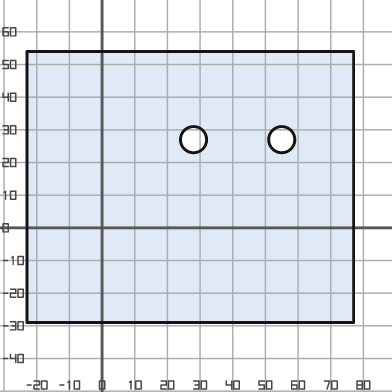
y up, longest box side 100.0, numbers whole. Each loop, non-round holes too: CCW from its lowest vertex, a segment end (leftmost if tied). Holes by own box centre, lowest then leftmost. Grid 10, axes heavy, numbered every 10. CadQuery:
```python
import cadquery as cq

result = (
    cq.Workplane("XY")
    .moveTo(-23.0, -29.0)
    .lineTo(77.0, -29.0)
    .lineTo(77.0, 54.0)
    .lineTo(-23.0, 54.0)
    .close()
    .moveTo(28.0, 27.0)
    .circle(4.0)
    .moveTo(55.0, 27.0)
    .circle(4.0)
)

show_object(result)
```